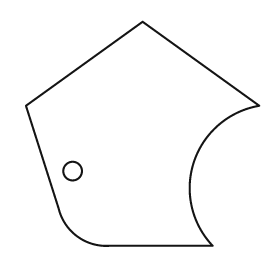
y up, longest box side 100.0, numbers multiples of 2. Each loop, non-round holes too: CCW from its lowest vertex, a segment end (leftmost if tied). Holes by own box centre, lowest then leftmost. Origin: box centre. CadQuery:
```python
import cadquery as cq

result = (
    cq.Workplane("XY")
    .moveTo(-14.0, -48.0)
    .lineTo(30.0, -48.0)
    .threePointArc((22.0, -12.0), (50.0, 12.0))
    .lineTo(0.0, 48.0)
    .lineTo(-50.0, 12.0)
    .lineTo(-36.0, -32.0)
    .threePointArc((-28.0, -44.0), (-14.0, -48.0))
    .close()
    .moveTo(-30.0, -16.0)
    .circle(4.0)
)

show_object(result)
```